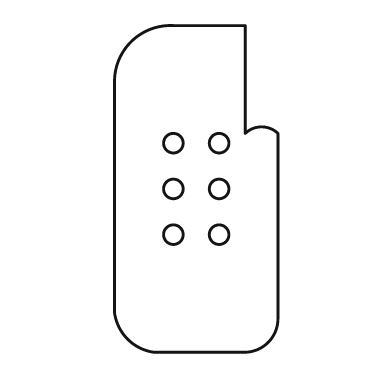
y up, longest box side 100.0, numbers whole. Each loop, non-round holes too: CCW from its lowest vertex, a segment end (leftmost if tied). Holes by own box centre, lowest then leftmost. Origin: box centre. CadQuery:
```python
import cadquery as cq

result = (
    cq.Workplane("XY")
    .moveTo(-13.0, -50.0)
    .lineTo(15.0, -50.0)
    .threePointArc((22.0, -47.0), (25.0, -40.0))
    .lineTo(25.0, 17.0)
    .threePointArc((20.0, 19.0), (15.0, 17.0))
    .lineTo(15.0, 50.0)
    .lineTo(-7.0, 50.0)
    .threePointArc((-20.0, 45.0), (-25.0, 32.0))
    .lineTo(-25.0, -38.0)
    .threePointArc((-21.0, -46.0), (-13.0, -50.0))
    .close()
    .moveTo(-7.0, -14.0)
    .circle(3.0)
    .moveTo(7.0, -14.0)
    .circle(3.0)
    .moveTo(-7.0, 0.0)
    .circle(3.0)
    .moveTo(7.0, 0.0)
    .circle(3.0)
    .moveTo(-7.0, 14.0)
    .circle(3.0)
    .moveTo(7.0, 14.0)
    .circle(3.0)
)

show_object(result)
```